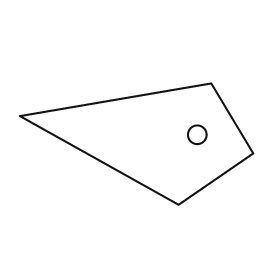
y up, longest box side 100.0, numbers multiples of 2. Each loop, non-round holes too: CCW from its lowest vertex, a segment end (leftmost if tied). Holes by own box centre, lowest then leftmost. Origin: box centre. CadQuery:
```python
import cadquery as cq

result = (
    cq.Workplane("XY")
    .moveTo(18.0, -26.0)
    .lineTo(50.0, -4.0)
    .lineTo(32.0, 26.0)
    .lineTo(-50.0, 12.0)
    .close()
    .moveTo(26.0, 4.0)
    .circle(4.0)
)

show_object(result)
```